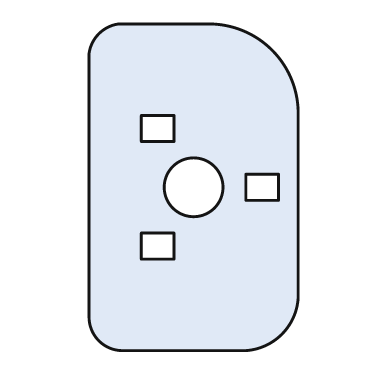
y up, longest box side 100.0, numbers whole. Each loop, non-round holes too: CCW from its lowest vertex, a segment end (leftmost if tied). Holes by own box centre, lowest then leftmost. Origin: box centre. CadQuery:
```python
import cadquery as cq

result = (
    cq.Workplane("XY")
    .moveTo(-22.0, -50.0)
    .lineTo(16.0, -50.0)
    .threePointArc((27.0, -45.0), (32.0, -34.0))
    .lineTo(32.0, 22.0)
    .threePointArc((24.0, 42.0), (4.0, 50.0))
    .lineTo(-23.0, 50.0)
    .threePointArc((-29.0, 47.0), (-32.0, 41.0))
    .lineTo(-32.0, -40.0)
    .threePointArc((-29.0, -47.0), (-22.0, -50.0))
    .close()
    .moveTo(-16.0, -22.0)
    .lineTo(-6.0, -22.0)
    .lineTo(-6.0, -14.0)
    .lineTo(-16.0, -14.0)
    .close()
    .moveTo(0.0, 0.0)
    .circle(9.0)
    .moveTo(16.0, -4.0)
    .lineTo(26.0, -4.0)
    .lineTo(26.0, 4.0)
    .lineTo(16.0, 4.0)
    .close()
    .moveTo(-16.0, 14.0)
    .lineTo(-6.0, 14.0)
    .lineTo(-6.0, 22.0)
    .lineTo(-16.0, 22.0)
    .close()
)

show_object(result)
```